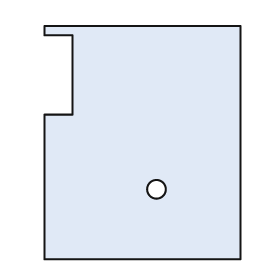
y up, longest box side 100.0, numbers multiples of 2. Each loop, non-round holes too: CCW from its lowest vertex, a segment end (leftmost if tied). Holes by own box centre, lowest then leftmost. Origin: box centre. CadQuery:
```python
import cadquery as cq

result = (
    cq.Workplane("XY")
    .moveTo(-42.0, -50.0)
    .lineTo(42.0, -50.0)
    .lineTo(42.0, 50.0)
    .lineTo(-42.0, 50.0)
    .lineTo(-42.0, 46.0)
    .lineTo(-30.0, 46.0)
    .lineTo(-30.0, 12.0)
    .lineTo(-42.0, 12.0)
    .close()
    .moveTo(6.0, -20.0)
    .circle(4.0)
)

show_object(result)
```